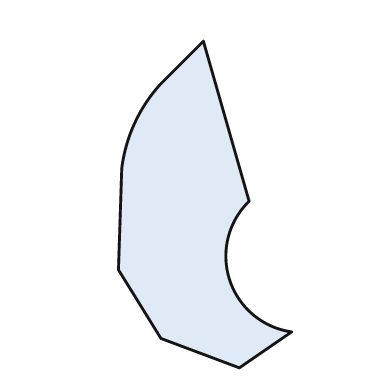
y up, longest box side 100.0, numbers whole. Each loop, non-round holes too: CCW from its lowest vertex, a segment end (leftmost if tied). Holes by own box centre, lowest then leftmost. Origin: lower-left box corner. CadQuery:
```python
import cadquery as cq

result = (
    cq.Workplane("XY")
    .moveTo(37.0, 0.0)
    .lineTo(53.0, 11.0)
    .threePointArc((34.0, 27.0), (40.0, 51.0))
    .lineTo(26.0, 100.0)
    .lineTo(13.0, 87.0)
    .threePointArc((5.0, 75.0), (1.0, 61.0))
    .lineTo(0.0, 30.0)
    .lineTo(13.0, 9.0)
    .close()
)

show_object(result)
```